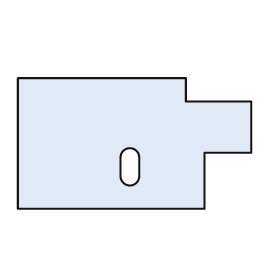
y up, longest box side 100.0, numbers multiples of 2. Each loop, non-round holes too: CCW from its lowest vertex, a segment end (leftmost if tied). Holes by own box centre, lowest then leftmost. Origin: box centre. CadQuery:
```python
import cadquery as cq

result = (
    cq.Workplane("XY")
    .moveTo(-50.0, -28.0)
    .lineTo(30.0, -28.0)
    .lineTo(30.0, -4.0)
    .lineTo(50.0, -4.0)
    .lineTo(50.0, 18.0)
    .lineTo(22.0, 18.0)
    .lineTo(22.0, 28.0)
    .lineTo(-50.0, 28.0)
    .close()
    .moveTo(-6.0, -14.0)
    .threePointArc((-2.0, -18.0), (2.0, -14.0))
    .lineTo(2.0, -6.0)
    .threePointArc((-2.0, -2.0), (-6.0, -6.0))
    .close()
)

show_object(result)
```